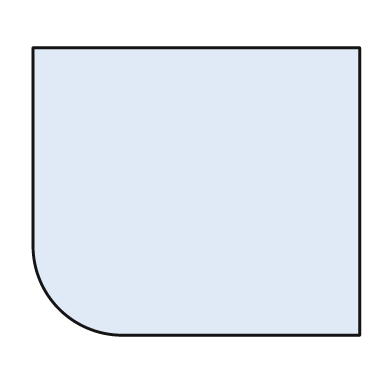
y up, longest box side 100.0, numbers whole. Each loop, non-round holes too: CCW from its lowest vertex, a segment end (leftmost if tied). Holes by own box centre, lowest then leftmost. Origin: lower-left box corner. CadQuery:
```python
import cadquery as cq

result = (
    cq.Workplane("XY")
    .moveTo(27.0, 0.0)
    .lineTo(100.0, 0.0)
    .lineTo(100.0, 88.0)
    .lineTo(0.0, 88.0)
    .lineTo(0.0, 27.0)
    .threePointArc((8.0, 8.0), (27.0, 0.0))
    .close()
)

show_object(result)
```